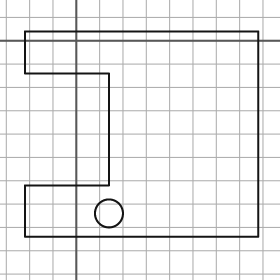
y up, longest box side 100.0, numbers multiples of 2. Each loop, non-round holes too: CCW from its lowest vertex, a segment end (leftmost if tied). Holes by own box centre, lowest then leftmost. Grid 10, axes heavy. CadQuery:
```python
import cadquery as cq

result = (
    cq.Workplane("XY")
    .moveTo(-22.0, -84.0)
    .lineTo(78.0, -84.0)
    .lineTo(78.0, 4.0)
    .lineTo(-22.0, 4.0)
    .lineTo(-22.0, -14.0)
    .lineTo(14.0, -14.0)
    .lineTo(14.0, -62.0)
    .lineTo(-22.0, -62.0)
    .close()
    .moveTo(14.0, -74.0)
    .circle(6.0)
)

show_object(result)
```